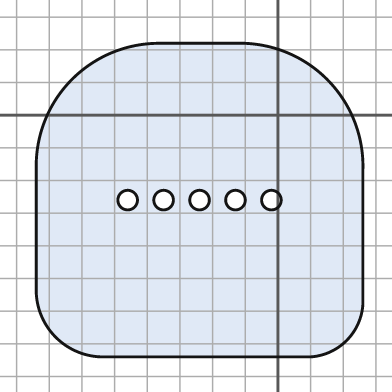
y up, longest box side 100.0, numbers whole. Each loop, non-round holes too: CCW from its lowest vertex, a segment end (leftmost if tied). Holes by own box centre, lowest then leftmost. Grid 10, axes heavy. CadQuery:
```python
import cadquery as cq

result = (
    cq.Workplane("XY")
    .moveTo(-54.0, -74.0)
    .lineTo(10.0, -74.0)
    .threePointArc((21.0, -69.0), (26.0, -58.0))
    .lineTo(26.0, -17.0)
    .threePointArc((15.0, 11.0), (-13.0, 22.0))
    .lineTo(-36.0, 22.0)
    .threePointArc((-63.0, 11.0), (-74.0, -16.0))
    .lineTo(-74.0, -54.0)
    .threePointArc((-68.0, -68.0), (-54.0, -74.0))
    .close()
    .moveTo(-46.0, -26.0)
    .circle(3.0)
    .moveTo(-35.0, -26.0)
    .circle(3.0)
    .moveTo(-24.0, -26.0)
    .circle(3.0)
    .moveTo(-13.0, -26.0)
    .circle(3.0)
    .moveTo(-2.0, -26.0)
    .circle(3.0)
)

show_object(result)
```